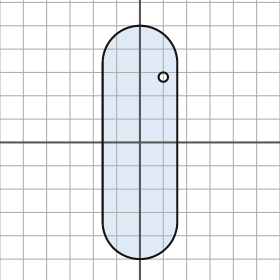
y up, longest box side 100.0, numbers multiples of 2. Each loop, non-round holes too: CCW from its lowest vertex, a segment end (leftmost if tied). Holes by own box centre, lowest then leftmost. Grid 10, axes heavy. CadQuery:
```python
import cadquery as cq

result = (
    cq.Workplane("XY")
    .moveTo(-16.0, -34.0)
    .threePointArc((0.0, -50.0), (16.0, -34.0))
    .lineTo(16.0, 34.0)
    .threePointArc((0.0, 50.0), (-16.0, 34.0))
    .close()
    .moveTo(10.0, 28.0)
    .circle(2.0)
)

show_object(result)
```